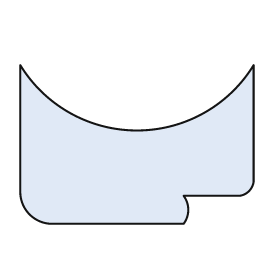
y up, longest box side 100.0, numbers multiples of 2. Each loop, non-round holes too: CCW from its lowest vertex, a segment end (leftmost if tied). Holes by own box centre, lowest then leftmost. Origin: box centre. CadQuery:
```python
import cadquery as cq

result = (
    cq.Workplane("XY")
    .moveTo(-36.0, -34.0)
    .lineTo(20.0, -34.0)
    .threePointArc((22.0, -28.0), (20.0, -22.0))
    .lineTo(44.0, -22.0)
    .threePointArc((48.0, -20.0), (50.0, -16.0))
    .lineTo(50.0, 34.0)
    .threePointArc((0.0, 6.0), (-50.0, 34.0))
    .lineTo(-50.0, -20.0)
    .threePointArc((-46.0, -30.0), (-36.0, -34.0))
    .close()
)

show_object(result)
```